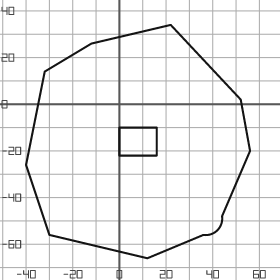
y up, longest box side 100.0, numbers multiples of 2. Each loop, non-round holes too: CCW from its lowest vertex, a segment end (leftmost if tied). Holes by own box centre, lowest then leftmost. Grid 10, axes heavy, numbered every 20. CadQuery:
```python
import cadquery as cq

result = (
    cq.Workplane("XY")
    .moveTo(12.0, -66.0)
    .lineTo(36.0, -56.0)
    .threePointArc((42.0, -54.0), (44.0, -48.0))
    .lineTo(56.0, -20.0)
    .lineTo(52.0, 2.0)
    .lineTo(22.0, 34.0)
    .lineTo(-12.0, 26.0)
    .lineTo(-32.0, 14.0)
    .lineTo(-40.0, -26.0)
    .lineTo(-30.0, -56.0)
    .close()
    .moveTo(0.0, -22.0)
    .lineTo(16.0, -22.0)
    .lineTo(16.0, -10.0)
    .lineTo(0.0, -10.0)
    .close()
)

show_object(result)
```